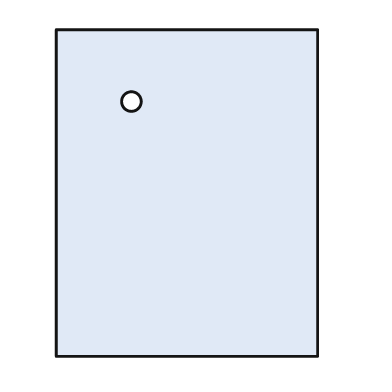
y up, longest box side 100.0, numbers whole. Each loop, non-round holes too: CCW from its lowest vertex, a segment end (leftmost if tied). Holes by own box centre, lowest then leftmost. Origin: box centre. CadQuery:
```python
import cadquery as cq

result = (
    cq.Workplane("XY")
    .moveTo(-40.0, -50.0)
    .lineTo(40.0, -50.0)
    .lineTo(40.0, 50.0)
    .lineTo(-40.0, 50.0)
    .close()
    .moveTo(-17.0, 28.0)
    .circle(3.0)
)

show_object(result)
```